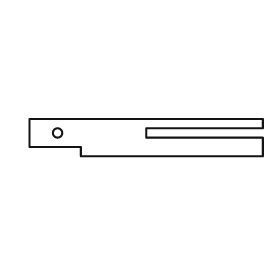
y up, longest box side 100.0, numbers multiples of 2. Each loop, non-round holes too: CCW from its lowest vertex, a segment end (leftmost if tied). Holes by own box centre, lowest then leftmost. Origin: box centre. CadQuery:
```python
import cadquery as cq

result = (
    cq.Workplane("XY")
    .moveTo(-28.0, -8.0)
    .lineTo(50.0, -8.0)
    .lineTo(50.0, 0.0)
    .lineTo(0.0, 0.0)
    .lineTo(0.0, 4.0)
    .lineTo(50.0, 4.0)
    .lineTo(50.0, 8.0)
    .lineTo(-50.0, 8.0)
    .lineTo(-50.0, -4.0)
    .lineTo(-28.0, -4.0)
    .close()
    .moveTo(-38.0, 2.0)
    .circle(2.0)
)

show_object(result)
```